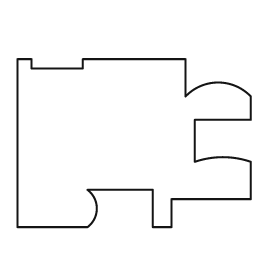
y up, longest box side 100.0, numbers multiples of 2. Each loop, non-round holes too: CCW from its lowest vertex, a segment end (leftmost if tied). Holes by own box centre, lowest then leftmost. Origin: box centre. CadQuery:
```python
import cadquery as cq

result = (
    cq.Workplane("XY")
    .moveTo(-50.0, -36.0)
    .lineTo(-20.0, -36.0)
    .threePointArc((-16.0, -28.0), (-20.0, -20.0))
    .lineTo(8.0, -20.0)
    .lineTo(8.0, -36.0)
    .lineTo(16.0, -36.0)
    .lineTo(16.0, -24.0)
    .lineTo(50.0, -24.0)
    .lineTo(50.0, -8.0)
    .threePointArc((38.0, -6.0), (26.0, -8.0))
    .lineTo(26.0, 10.0)
    .lineTo(50.0, 10.0)
    .lineTo(50.0, 20.0)
    .threePointArc((36.0, 26.0), (22.0, 20.0))
    .lineTo(22.0, 36.0)
    .lineTo(-22.0, 36.0)
    .lineTo(-22.0, 32.0)
    .lineTo(-44.0, 32.0)
    .lineTo(-44.0, 36.0)
    .lineTo(-50.0, 36.0)
    .close()
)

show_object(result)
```